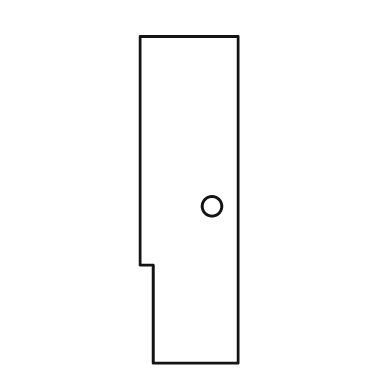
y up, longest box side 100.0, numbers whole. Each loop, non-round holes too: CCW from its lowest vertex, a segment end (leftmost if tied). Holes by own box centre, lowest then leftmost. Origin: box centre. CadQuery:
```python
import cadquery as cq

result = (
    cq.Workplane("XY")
    .moveTo(-11.0, -50.0)
    .lineTo(15.0, -50.0)
    .lineTo(15.0, 50.0)
    .lineTo(-15.0, 50.0)
    .lineTo(-15.0, -20.0)
    .lineTo(-11.0, -20.0)
    .close()
    .moveTo(7.0, -2.0)
    .circle(3.0)
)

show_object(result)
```